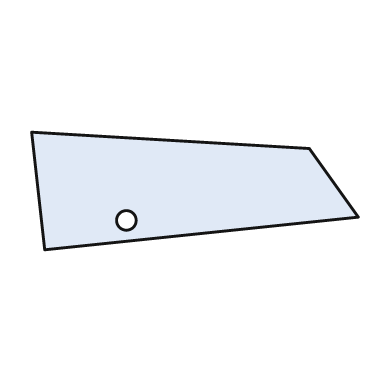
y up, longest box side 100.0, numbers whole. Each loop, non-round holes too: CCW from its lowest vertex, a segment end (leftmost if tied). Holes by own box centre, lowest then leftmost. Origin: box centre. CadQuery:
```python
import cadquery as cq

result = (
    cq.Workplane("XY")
    .moveTo(-46.0, -18.0)
    .lineTo(50.0, -8.0)
    .lineTo(35.0, 13.0)
    .lineTo(-50.0, 18.0)
    .close()
    .moveTo(-21.0, -9.0)
    .circle(3.0)
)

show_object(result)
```